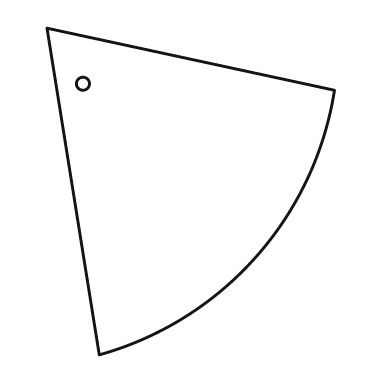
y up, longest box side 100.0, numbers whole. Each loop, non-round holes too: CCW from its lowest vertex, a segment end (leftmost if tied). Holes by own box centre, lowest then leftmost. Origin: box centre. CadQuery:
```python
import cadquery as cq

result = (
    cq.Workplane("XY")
    .moveTo(-28.0, -50.0)
    .threePointArc((20.0, -20.0), (44.0, 31.0))
    .lineTo(-44.0, 50.0)
    .close()
    .moveTo(-33.0, 33.0)
    .circle(2.0)
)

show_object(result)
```